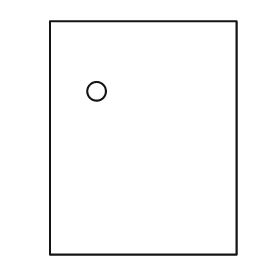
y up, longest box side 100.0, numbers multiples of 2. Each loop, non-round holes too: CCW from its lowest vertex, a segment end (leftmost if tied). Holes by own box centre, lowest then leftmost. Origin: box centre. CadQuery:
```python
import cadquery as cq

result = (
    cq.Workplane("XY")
    .moveTo(-40.0, -50.0)
    .lineTo(40.0, -50.0)
    .lineTo(40.0, 50.0)
    .lineTo(-40.0, 50.0)
    .close()
    .moveTo(-20.0, 20.0)
    .circle(4.0)
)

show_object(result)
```